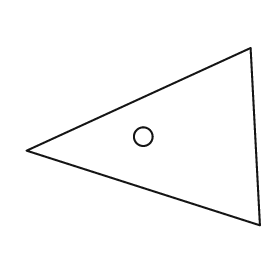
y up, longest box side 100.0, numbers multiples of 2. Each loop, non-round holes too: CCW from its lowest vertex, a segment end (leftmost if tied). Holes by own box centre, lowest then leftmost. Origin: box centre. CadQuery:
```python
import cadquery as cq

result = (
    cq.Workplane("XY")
    .moveTo(50.0, -38.0)
    .lineTo(46.0, 38.0)
    .lineTo(-50.0, -6.0)
    .close()
    .moveTo(0.0, 0.0)
    .circle(4.0)
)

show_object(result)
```